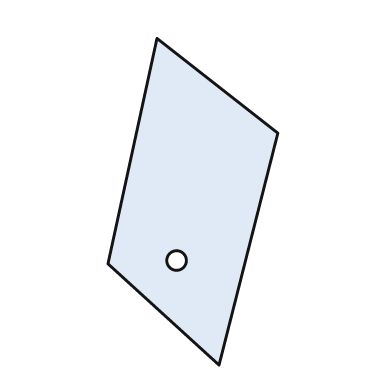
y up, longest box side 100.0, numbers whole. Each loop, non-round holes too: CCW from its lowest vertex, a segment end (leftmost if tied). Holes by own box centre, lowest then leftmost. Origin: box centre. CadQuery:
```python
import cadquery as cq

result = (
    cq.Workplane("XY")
    .moveTo(8.0, -50.0)
    .lineTo(26.0, 21.0)
    .lineTo(-11.0, 50.0)
    .lineTo(-26.0, -19.0)
    .close()
    .moveTo(-5.0, -18.0)
    .circle(3.0)
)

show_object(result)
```